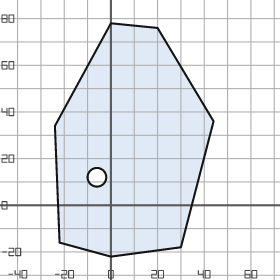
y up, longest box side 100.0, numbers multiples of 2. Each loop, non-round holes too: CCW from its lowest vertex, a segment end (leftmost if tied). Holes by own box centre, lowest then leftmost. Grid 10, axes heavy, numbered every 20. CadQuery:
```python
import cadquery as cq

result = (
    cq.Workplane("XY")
    .moveTo(0.0, -22.0)
    .lineTo(30.0, -18.0)
    .lineTo(44.0, 36.0)
    .lineTo(20.0, 76.0)
    .lineTo(0.0, 78.0)
    .lineTo(-24.0, 34.0)
    .lineTo(-22.0, -16.0)
    .close()
    .moveTo(-6.0, 12.0)
    .circle(4.0)
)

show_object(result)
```